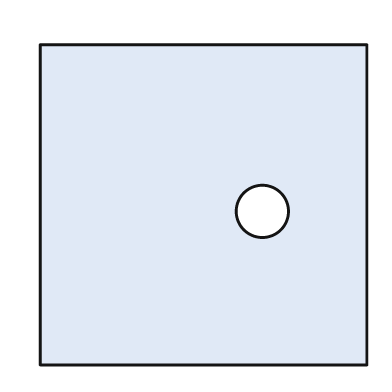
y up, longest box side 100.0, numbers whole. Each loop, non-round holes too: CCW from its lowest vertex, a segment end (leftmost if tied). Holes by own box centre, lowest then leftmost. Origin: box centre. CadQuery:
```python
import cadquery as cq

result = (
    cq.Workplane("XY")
    .moveTo(-50.0, -49.0)
    .lineTo(50.0, -49.0)
    .lineTo(50.0, 49.0)
    .lineTo(-50.0, 49.0)
    .close()
    .moveTo(18.0, -2.0)
    .circle(8.0)
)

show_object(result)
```